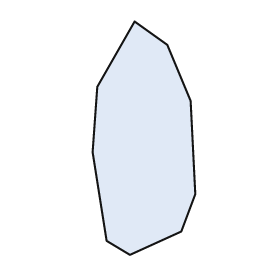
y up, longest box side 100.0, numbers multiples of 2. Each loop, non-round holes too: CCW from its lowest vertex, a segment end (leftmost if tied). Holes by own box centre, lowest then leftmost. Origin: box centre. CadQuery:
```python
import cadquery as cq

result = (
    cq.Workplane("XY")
    .moveTo(-6.0, -50.0)
    .lineTo(16.0, -40.0)
    .lineTo(22.0, -24.0)
    .lineTo(20.0, 16.0)
    .lineTo(10.0, 40.0)
    .lineTo(-4.0, 50.0)
    .lineTo(-20.0, 22.0)
    .lineTo(-22.0, -6.0)
    .lineTo(-16.0, -44.0)
    .close()
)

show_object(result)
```